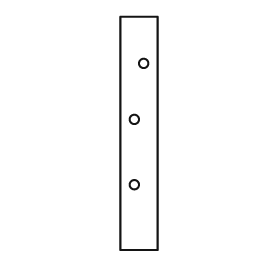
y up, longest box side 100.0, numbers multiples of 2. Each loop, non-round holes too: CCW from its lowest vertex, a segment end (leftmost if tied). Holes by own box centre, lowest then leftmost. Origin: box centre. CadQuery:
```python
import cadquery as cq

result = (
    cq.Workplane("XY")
    .moveTo(-8.0, -50.0)
    .lineTo(8.0, -50.0)
    .lineTo(8.0, 50.0)
    .lineTo(-8.0, 50.0)
    .close()
    .moveTo(-2.0, -22.0)
    .circle(2.0)
    .moveTo(-2.0, 6.0)
    .circle(2.0)
    .moveTo(2.0, 30.0)
    .circle(2.0)
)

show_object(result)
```